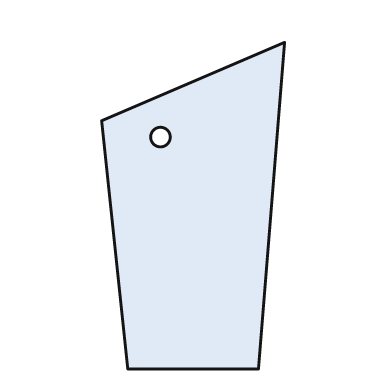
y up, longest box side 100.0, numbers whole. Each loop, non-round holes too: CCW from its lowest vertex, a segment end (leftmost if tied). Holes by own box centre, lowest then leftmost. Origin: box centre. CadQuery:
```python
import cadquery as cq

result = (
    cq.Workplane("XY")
    .moveTo(-20.0, -50.0)
    .lineTo(20.0, -50.0)
    .lineTo(28.0, 50.0)
    .lineTo(-28.0, 26.0)
    .close()
    .moveTo(-10.0, 21.0)
    .circle(3.0)
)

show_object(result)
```